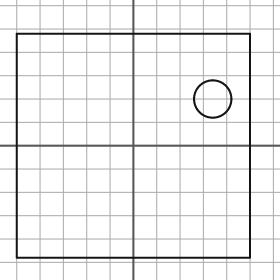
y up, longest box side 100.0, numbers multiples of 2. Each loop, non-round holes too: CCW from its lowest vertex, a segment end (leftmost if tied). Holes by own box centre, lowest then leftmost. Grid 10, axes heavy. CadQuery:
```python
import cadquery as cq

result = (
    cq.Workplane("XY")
    .moveTo(-50.0, -48.0)
    .lineTo(50.0, -48.0)
    .lineTo(50.0, 48.0)
    .lineTo(-50.0, 48.0)
    .close()
    .moveTo(34.0, 20.0)
    .circle(8.0)
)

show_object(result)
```